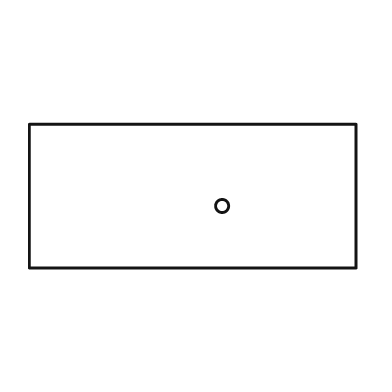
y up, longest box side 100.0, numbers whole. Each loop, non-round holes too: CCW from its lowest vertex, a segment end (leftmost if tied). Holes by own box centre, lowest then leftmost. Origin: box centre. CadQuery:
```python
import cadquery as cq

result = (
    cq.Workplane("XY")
    .moveTo(-50.0, -22.0)
    .lineTo(50.0, -22.0)
    .lineTo(50.0, 22.0)
    .lineTo(-50.0, 22.0)
    .close()
    .moveTo(9.0, -3.0)
    .circle(2.0)
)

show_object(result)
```